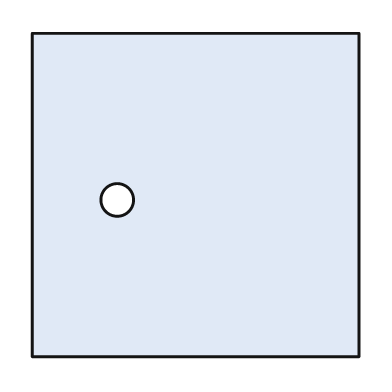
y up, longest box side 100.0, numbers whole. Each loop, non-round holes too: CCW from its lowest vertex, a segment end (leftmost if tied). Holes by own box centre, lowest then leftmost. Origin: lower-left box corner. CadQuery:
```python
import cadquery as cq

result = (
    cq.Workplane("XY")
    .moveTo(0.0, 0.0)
    .lineTo(100.0, 0.0)
    .lineTo(100.0, 99.0)
    .lineTo(0.0, 99.0)
    .close()
    .moveTo(26.0, 48.0)
    .circle(5.0)
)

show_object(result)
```